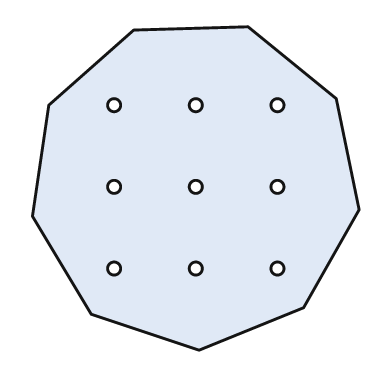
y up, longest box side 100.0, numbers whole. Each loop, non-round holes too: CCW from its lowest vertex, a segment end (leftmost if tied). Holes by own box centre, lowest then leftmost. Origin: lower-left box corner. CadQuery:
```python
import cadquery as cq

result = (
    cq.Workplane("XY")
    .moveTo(51.0, 0.0)
    .lineTo(83.0, 13.0)
    .lineTo(100.0, 43.0)
    .lineTo(93.0, 77.0)
    .lineTo(66.0, 99.0)
    .lineTo(31.0, 98.0)
    .lineTo(5.0, 75.0)
    .lineTo(0.0, 41.0)
    .lineTo(18.0, 11.0)
    .close()
    .moveTo(25.0, 25.0)
    .circle(2.0)
    .moveTo(50.0, 25.0)
    .circle(2.0)
    .moveTo(75.0, 25.0)
    .circle(2.0)
    .moveTo(25.0, 50.0)
    .circle(2.0)
    .moveTo(50.0, 50.0)
    .circle(2.0)
    .moveTo(75.0, 50.0)
    .circle(2.0)
    .moveTo(25.0, 75.0)
    .circle(2.0)
    .moveTo(50.0, 75.0)
    .circle(2.0)
    .moveTo(75.0, 75.0)
    .circle(2.0)
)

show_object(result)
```